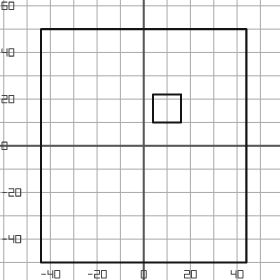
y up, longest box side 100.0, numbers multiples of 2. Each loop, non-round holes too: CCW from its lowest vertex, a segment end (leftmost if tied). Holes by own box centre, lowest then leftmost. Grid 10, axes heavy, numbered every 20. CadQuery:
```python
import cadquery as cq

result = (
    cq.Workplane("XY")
    .moveTo(-44.0, -50.0)
    .lineTo(44.0, -50.0)
    .lineTo(44.0, 50.0)
    .lineTo(-44.0, 50.0)
    .close()
    .moveTo(4.0, 10.0)
    .lineTo(16.0, 10.0)
    .lineTo(16.0, 22.0)
    .lineTo(4.0, 22.0)
    .close()
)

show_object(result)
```